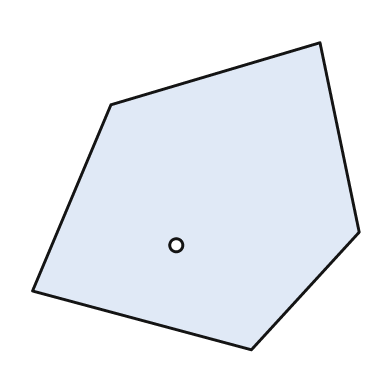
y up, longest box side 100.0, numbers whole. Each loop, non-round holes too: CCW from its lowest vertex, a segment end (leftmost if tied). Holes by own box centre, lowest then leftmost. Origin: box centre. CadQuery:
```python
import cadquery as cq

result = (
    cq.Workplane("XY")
    .moveTo(17.0, -47.0)
    .lineTo(50.0, -11.0)
    .lineTo(38.0, 47.0)
    .lineTo(-26.0, 28.0)
    .lineTo(-50.0, -29.0)
    .close()
    .moveTo(-6.0, -15.0)
    .circle(2.0)
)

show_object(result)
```